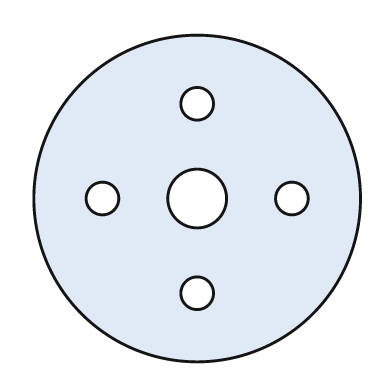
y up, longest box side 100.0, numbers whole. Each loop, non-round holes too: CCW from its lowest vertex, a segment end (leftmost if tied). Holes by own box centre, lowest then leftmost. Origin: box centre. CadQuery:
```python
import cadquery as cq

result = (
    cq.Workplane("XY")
    .moveTo(0.0, 0.0)
    .circle(50.0)
    .moveTo(0.0, -29.0)
    .circle(5.0)
    .moveTo(-29.0, 0.0)
    .circle(5.0)
    .moveTo(0.0, 0.0)
    .circle(9.0)
    .moveTo(29.0, 0.0)
    .circle(5.0)
    .moveTo(0.0, 29.0)
    .circle(5.0)
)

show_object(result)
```